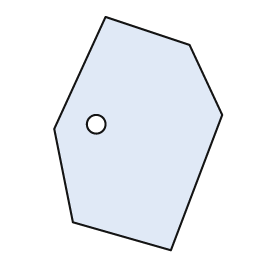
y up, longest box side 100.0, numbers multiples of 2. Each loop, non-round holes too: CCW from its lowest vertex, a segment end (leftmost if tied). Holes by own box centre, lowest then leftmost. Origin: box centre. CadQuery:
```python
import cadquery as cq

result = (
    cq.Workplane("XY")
    .moveTo(14.0, -50.0)
    .lineTo(36.0, 8.0)
    .lineTo(22.0, 38.0)
    .lineTo(-14.0, 50.0)
    .lineTo(-36.0, 2.0)
    .lineTo(-28.0, -38.0)
    .close()
    .moveTo(-18.0, 4.0)
    .circle(4.0)
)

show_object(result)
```